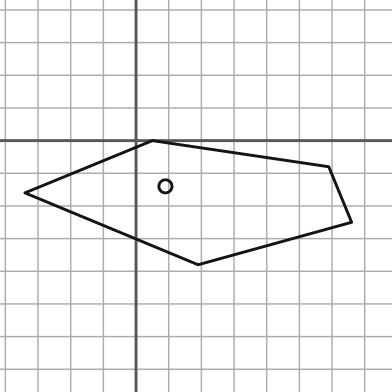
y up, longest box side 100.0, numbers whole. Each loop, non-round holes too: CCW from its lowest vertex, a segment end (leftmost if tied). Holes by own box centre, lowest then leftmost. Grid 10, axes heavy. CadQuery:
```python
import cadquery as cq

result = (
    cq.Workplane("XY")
    .moveTo(19.0, -38.0)
    .lineTo(66.0, -25.0)
    .lineTo(59.0, -8.0)
    .lineTo(5.0, 0.0)
    .lineTo(-34.0, -16.0)
    .close()
    .moveTo(9.0, -14.0)
    .circle(2.0)
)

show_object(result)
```